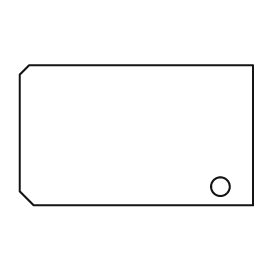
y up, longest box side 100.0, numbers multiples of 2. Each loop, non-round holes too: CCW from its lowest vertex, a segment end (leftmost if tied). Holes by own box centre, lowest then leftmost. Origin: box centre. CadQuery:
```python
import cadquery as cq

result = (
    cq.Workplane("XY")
    .moveTo(-44.0, -30.0)
    .lineTo(50.0, -30.0)
    .lineTo(50.0, 30.0)
    .lineTo(-46.0, 30.0)
    .lineTo(-50.0, 26.0)
    .lineTo(-50.0, -24.0)
    .close()
    .moveTo(36.0, -22.0)
    .circle(4.0)
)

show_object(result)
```